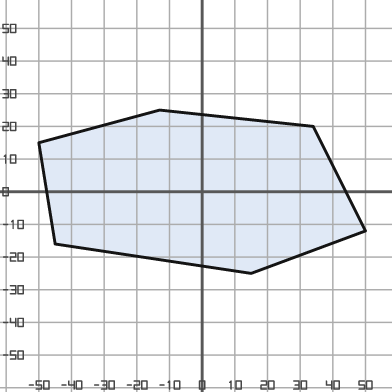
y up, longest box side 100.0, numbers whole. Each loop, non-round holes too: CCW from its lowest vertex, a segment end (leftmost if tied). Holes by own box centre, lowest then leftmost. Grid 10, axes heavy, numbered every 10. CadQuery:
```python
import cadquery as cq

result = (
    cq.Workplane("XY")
    .moveTo(15.0, -25.0)
    .lineTo(50.0, -12.0)
    .lineTo(34.0, 20.0)
    .lineTo(-13.0, 25.0)
    .lineTo(-50.0, 15.0)
    .lineTo(-45.0, -16.0)
    .close()
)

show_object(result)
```